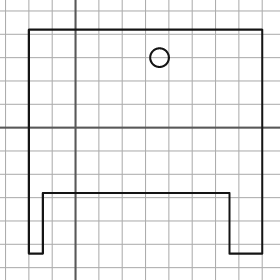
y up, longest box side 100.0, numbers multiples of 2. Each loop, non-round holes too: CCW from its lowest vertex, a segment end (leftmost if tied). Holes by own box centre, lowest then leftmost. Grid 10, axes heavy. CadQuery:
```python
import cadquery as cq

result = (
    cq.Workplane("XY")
    .moveTo(-20.0, -54.0)
    .lineTo(-14.0, -54.0)
    .lineTo(-14.0, -28.0)
    .lineTo(66.0, -28.0)
    .lineTo(66.0, -54.0)
    .lineTo(80.0, -54.0)
    .lineTo(80.0, 42.0)
    .lineTo(-20.0, 42.0)
    .close()
    .moveTo(36.0, 30.0)
    .circle(4.0)
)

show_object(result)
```